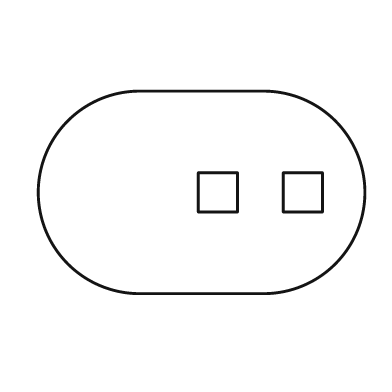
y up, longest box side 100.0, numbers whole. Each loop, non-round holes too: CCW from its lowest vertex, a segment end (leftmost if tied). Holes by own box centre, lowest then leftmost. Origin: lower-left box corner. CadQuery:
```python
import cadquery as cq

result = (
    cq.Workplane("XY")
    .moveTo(31.0, 0.0)
    .lineTo(69.0, 0.0)
    .threePointArc((100.0, 31.0), (69.0, 62.0))
    .lineTo(31.0, 62.0)
    .threePointArc((0.0, 31.0), (31.0, 0.0))
    .close()
    .moveTo(49.0, 25.0)
    .lineTo(61.0, 25.0)
    .lineTo(61.0, 37.0)
    .lineTo(49.0, 37.0)
    .close()
    .moveTo(75.0, 25.0)
    .lineTo(87.0, 25.0)
    .lineTo(87.0, 37.0)
    .lineTo(75.0, 37.0)
    .close()
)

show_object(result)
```